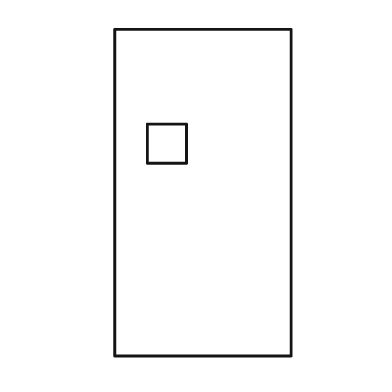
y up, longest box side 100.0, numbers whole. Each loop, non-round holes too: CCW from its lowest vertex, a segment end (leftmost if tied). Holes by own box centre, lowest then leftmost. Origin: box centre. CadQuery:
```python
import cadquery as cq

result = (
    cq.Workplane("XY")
    .moveTo(-27.0, -50.0)
    .lineTo(27.0, -50.0)
    .lineTo(27.0, 50.0)
    .lineTo(-27.0, 50.0)
    .close()
    .moveTo(-17.0, 9.0)
    .lineTo(-5.0, 9.0)
    .lineTo(-5.0, 21.0)
    .lineTo(-17.0, 21.0)
    .close()
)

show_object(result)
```